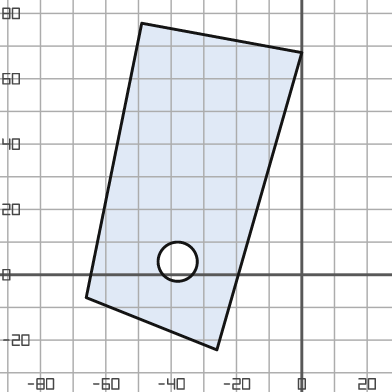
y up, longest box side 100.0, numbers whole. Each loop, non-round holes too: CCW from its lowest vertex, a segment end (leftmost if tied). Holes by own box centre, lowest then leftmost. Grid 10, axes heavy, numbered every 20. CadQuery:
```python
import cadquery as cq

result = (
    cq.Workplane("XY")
    .moveTo(-26.0, -23.0)
    .lineTo(0.0, 68.0)
    .lineTo(-49.0, 77.0)
    .lineTo(-66.0, -7.0)
    .close()
    .moveTo(-38.0, 4.0)
    .circle(6.0)
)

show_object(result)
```